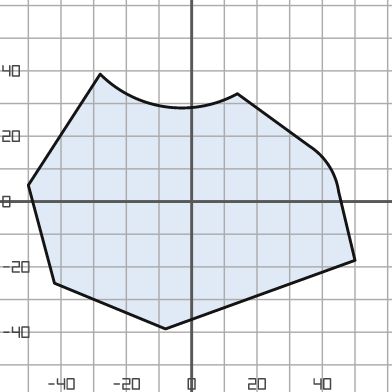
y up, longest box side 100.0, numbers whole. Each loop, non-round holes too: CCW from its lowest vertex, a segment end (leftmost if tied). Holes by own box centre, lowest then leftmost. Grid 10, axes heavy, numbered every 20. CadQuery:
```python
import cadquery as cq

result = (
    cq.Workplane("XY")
    .moveTo(-8.0, -39.0)
    .lineTo(50.0, -18.0)
    .lineTo(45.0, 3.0)
    .threePointArc((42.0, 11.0), (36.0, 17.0))
    .lineTo(14.0, 33.0)
    .threePointArc((-8.0, 29.0), (-28.0, 39.0))
    .lineTo(-50.0, 5.0)
    .lineTo(-42.0, -25.0)
    .close()
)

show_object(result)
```